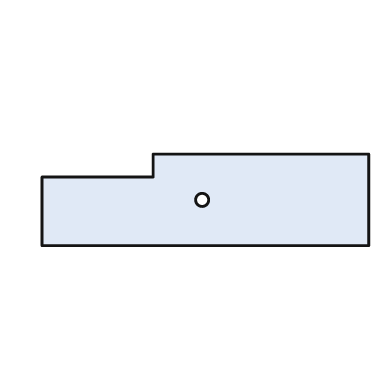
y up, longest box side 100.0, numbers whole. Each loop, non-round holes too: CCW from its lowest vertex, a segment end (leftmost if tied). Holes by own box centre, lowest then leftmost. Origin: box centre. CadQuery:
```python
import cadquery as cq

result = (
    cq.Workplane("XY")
    .moveTo(-50.0, -14.0)
    .lineTo(50.0, -14.0)
    .lineTo(50.0, 14.0)
    .lineTo(-16.0, 14.0)
    .lineTo(-16.0, 7.0)
    .lineTo(-50.0, 7.0)
    .close()
    .moveTo(-1.0, 0.0)
    .circle(2.0)
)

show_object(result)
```